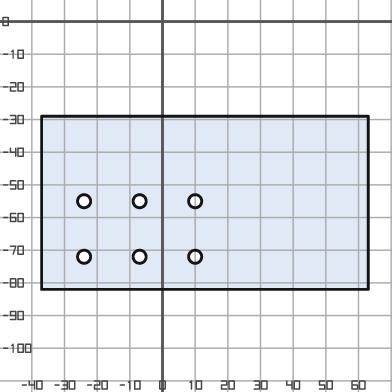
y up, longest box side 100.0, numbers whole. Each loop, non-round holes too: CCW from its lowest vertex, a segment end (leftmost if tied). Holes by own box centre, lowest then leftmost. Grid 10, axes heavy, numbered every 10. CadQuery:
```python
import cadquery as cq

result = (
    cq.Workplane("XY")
    .moveTo(-37.0, -82.0)
    .lineTo(63.0, -82.0)
    .lineTo(63.0, -29.0)
    .lineTo(-37.0, -29.0)
    .close()
    .moveTo(-24.0, -72.0)
    .circle(2.0)
    .moveTo(-7.0, -72.0)
    .circle(2.0)
    .moveTo(10.0, -72.0)
    .circle(2.0)
    .moveTo(-24.0, -55.0)
    .circle(2.0)
    .moveTo(-7.0, -55.0)
    .circle(2.0)
    .moveTo(10.0, -55.0)
    .circle(2.0)
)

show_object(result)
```